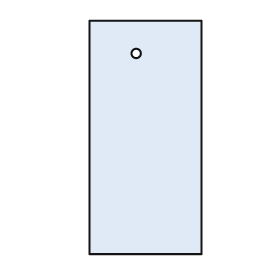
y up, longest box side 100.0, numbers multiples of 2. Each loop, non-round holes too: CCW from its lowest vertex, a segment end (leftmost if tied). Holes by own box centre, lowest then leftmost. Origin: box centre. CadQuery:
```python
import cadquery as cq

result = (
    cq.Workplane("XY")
    .moveTo(-24.0, -50.0)
    .lineTo(24.0, -50.0)
    .lineTo(24.0, 50.0)
    .lineTo(-24.0, 50.0)
    .close()
    .moveTo(-4.0, 36.0)
    .circle(2.0)
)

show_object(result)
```